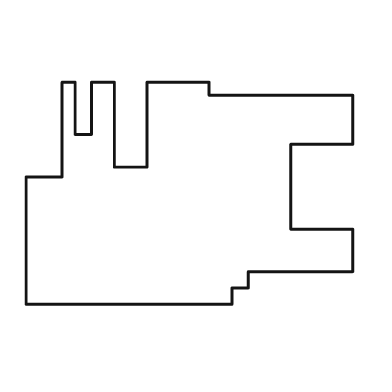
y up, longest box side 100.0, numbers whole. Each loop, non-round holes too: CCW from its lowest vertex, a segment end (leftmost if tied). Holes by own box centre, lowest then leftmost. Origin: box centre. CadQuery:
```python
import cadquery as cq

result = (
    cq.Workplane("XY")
    .moveTo(-50.0, -34.0)
    .lineTo(13.0, -34.0)
    .lineTo(13.0, -29.0)
    .lineTo(18.0, -29.0)
    .lineTo(18.0, -24.0)
    .lineTo(50.0, -24.0)
    .lineTo(50.0, -11.0)
    .lineTo(31.0, -11.0)
    .lineTo(31.0, 15.0)
    .lineTo(50.0, 15.0)
    .lineTo(50.0, 30.0)
    .lineTo(6.0, 30.0)
    .lineTo(6.0, 34.0)
    .lineTo(-13.0, 34.0)
    .lineTo(-13.0, 8.0)
    .lineTo(-23.0, 8.0)
    .lineTo(-23.0, 34.0)
    .lineTo(-30.0, 34.0)
    .lineTo(-30.0, 18.0)
    .lineTo(-35.0, 18.0)
    .lineTo(-35.0, 34.0)
    .lineTo(-39.0, 34.0)
    .lineTo(-39.0, 5.0)
    .lineTo(-50.0, 5.0)
    .close()
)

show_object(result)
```